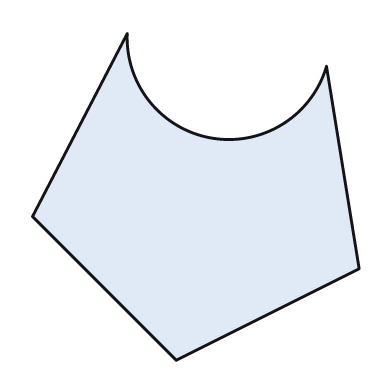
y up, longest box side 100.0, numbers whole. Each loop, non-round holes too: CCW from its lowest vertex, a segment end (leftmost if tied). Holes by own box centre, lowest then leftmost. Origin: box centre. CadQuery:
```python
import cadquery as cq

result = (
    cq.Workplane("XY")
    .moveTo(-6.0, -50.0)
    .lineTo(50.0, -22.0)
    .lineTo(40.0, 40.0)
    .threePointArc((5.0, 18.0), (-21.0, 50.0))
    .lineTo(-50.0, -6.0)
    .close()
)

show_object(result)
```